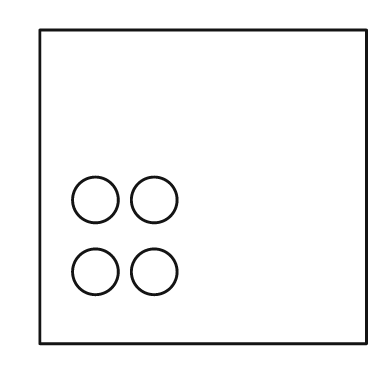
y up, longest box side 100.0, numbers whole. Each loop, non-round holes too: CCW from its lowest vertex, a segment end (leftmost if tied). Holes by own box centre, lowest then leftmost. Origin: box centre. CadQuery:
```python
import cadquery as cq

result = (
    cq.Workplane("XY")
    .moveTo(-50.0, -48.0)
    .lineTo(50.0, -48.0)
    .lineTo(50.0, 48.0)
    .lineTo(-50.0, 48.0)
    .close()
    .moveTo(-33.0, -26.0)
    .circle(7.0)
    .moveTo(-15.0, -26.0)
    .circle(7.0)
    .moveTo(-33.0, -4.0)
    .circle(7.0)
    .moveTo(-15.0, -4.0)
    .circle(7.0)
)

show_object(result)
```